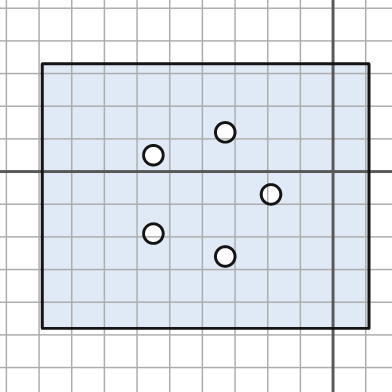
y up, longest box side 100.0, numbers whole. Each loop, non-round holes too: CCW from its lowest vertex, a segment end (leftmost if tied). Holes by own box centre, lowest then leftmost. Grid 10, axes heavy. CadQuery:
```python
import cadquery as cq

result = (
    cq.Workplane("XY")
    .moveTo(-89.0, -48.0)
    .lineTo(11.0, -48.0)
    .lineTo(11.0, 33.0)
    .lineTo(-89.0, 33.0)
    .close()
    .moveTo(-33.0, -26.0)
    .circle(3.0)
    .moveTo(-55.0, -19.0)
    .circle(3.0)
    .moveTo(-19.0, -7.0)
    .circle(3.0)
    .moveTo(-55.0, 5.0)
    .circle(3.0)
    .moveTo(-33.0, 12.0)
    .circle(3.0)
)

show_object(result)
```